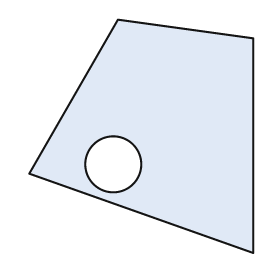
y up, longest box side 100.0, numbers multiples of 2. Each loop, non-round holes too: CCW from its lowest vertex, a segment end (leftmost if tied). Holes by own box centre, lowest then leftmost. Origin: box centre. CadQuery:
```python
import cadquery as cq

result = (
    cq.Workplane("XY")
    .moveTo(48.0, -50.0)
    .lineTo(48.0, 42.0)
    .lineTo(-10.0, 50.0)
    .lineTo(-48.0, -16.0)
    .close()
    .moveTo(-12.0, -12.0)
    .circle(12.0)
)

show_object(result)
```